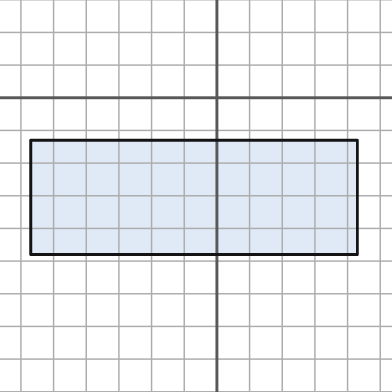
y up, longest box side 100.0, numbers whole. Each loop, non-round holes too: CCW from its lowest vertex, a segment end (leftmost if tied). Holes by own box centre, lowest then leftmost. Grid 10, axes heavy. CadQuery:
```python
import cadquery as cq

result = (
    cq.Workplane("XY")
    .moveTo(-57.0, -48.0)
    .lineTo(43.0, -48.0)
    .lineTo(43.0, -13.0)
    .lineTo(-57.0, -13.0)
    .close()
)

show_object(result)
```